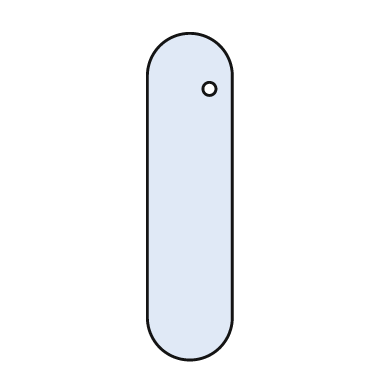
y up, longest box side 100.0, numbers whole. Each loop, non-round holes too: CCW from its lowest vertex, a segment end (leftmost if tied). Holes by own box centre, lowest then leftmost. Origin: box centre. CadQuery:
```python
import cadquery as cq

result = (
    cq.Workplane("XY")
    .moveTo(-13.0, -37.0)
    .threePointArc((0.0, -50.0), (13.0, -37.0))
    .lineTo(13.0, 37.0)
    .threePointArc((0.0, 50.0), (-13.0, 37.0))
    .close()
    .moveTo(6.0, 33.0)
    .circle(2.0)
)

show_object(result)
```